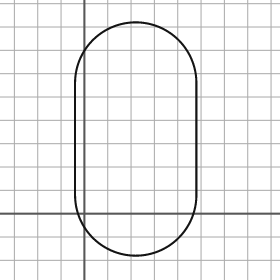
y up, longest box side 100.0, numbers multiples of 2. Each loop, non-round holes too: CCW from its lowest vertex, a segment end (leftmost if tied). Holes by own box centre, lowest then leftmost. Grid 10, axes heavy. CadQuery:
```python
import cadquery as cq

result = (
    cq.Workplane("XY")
    .moveTo(-4.0, 8.0)
    .threePointArc((22.0, -18.0), (48.0, 8.0))
    .lineTo(48.0, 56.0)
    .threePointArc((22.0, 82.0), (-4.0, 56.0))
    .close()
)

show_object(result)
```